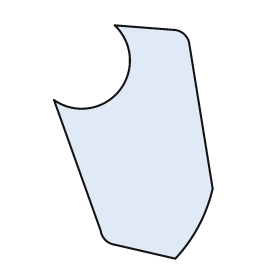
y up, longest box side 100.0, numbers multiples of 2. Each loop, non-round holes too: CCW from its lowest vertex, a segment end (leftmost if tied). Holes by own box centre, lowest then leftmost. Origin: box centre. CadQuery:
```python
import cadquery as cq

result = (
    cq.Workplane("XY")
    .moveTo(18.0, -50.0)
    .threePointArc((28.0, -36.0), (34.0, -20.0))
    .lineTo(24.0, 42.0)
    .threePointArc((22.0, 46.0), (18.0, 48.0))
    .lineTo(-8.0, 50.0)
    .threePointArc((-6.0, 22.0), (-34.0, 18.0))
    .lineTo(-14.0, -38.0)
    .threePointArc((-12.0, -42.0), (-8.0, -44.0))
    .close()
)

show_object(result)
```